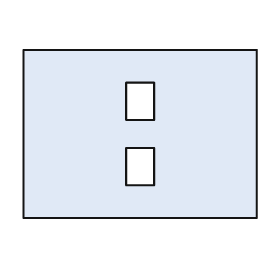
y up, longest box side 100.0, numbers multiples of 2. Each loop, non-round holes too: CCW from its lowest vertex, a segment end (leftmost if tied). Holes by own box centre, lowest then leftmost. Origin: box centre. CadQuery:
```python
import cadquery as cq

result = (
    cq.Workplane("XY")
    .moveTo(-50.0, -36.0)
    .lineTo(50.0, -36.0)
    .lineTo(50.0, 36.0)
    .lineTo(-50.0, 36.0)
    .close()
    .moveTo(-6.0, -22.0)
    .lineTo(6.0, -22.0)
    .lineTo(6.0, -6.0)
    .lineTo(-6.0, -6.0)
    .close()
    .moveTo(-6.0, 6.0)
    .lineTo(6.0, 6.0)
    .lineTo(6.0, 22.0)
    .lineTo(-6.0, 22.0)
    .close()
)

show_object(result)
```